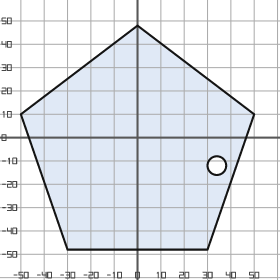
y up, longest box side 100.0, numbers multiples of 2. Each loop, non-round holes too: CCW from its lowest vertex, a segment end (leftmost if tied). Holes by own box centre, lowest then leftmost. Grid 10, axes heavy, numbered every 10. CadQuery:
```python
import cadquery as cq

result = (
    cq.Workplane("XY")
    .moveTo(-30.0, -48.0)
    .lineTo(30.0, -48.0)
    .lineTo(50.0, 10.0)
    .lineTo(0.0, 48.0)
    .lineTo(-50.0, 10.0)
    .close()
    .moveTo(34.0, -12.0)
    .circle(4.0)
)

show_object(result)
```